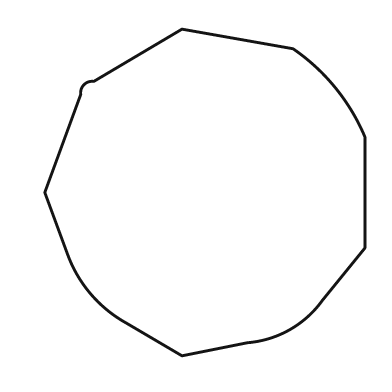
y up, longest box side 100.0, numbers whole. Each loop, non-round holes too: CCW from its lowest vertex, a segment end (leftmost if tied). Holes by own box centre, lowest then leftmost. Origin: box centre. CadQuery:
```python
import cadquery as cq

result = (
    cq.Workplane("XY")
    .moveTo(-7.0, -50.0)
    .lineTo(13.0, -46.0)
    .threePointArc((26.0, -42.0), (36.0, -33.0))
    .lineTo(49.0, -17.0)
    .lineTo(49.0, 17.0)
    .threePointArc((40.0, 32.0), (27.0, 44.0))
    .lineTo(-7.0, 50.0)
    .lineTo(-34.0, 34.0)
    .threePointArc((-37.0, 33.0), (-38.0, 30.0))
    .lineTo(-49.0, 0.0)
    .lineTo(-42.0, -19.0)
    .threePointArc((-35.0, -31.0), (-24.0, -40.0))
    .close()
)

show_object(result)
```